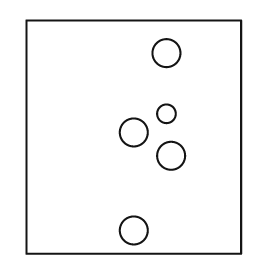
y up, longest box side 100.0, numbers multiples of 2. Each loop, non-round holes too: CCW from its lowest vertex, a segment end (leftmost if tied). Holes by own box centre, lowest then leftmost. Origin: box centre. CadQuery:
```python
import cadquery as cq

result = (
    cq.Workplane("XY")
    .moveTo(-46.0, -50.0)
    .lineTo(46.0, -50.0)
    .lineTo(46.0, 50.0)
    .lineTo(-46.0, 50.0)
    .close()
    .moveTo(0.0, -40.0)
    .circle(6.0)
    .moveTo(16.0, -8.0)
    .circle(6.0)
    .moveTo(0.0, 2.0)
    .circle(6.0)
    .moveTo(14.0, 10.0)
    .circle(4.0)
    .moveTo(14.0, 36.0)
    .circle(6.0)
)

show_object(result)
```